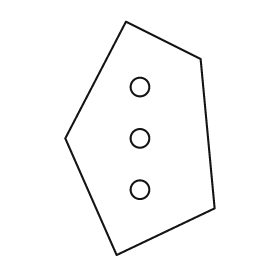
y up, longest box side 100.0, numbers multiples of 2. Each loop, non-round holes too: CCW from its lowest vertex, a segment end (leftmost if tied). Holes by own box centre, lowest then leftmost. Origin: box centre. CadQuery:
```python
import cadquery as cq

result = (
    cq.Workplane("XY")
    .moveTo(-10.0, -50.0)
    .lineTo(32.0, -30.0)
    .lineTo(26.0, 34.0)
    .lineTo(-6.0, 50.0)
    .lineTo(-32.0, 0.0)
    .close()
    .moveTo(0.0, -22.0)
    .circle(4.0)
    .moveTo(0.0, 0.0)
    .circle(4.0)
    .moveTo(0.0, 22.0)
    .circle(4.0)
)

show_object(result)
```